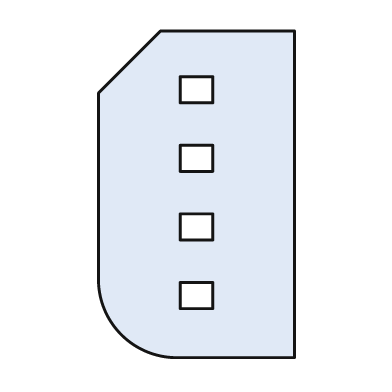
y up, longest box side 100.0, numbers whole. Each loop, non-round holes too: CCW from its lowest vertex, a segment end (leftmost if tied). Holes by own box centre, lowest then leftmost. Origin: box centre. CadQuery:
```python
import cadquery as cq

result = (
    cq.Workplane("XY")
    .moveTo(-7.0, -50.0)
    .lineTo(30.0, -50.0)
    .lineTo(30.0, 50.0)
    .lineTo(-11.0, 50.0)
    .lineTo(-30.0, 31.0)
    .lineTo(-30.0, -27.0)
    .threePointArc((-23.0, -43.0), (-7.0, -50.0))
    .close()
    .moveTo(-5.0, -35.0)
    .lineTo(5.0, -35.0)
    .lineTo(5.0, -27.0)
    .lineTo(-5.0, -27.0)
    .close()
    .moveTo(-5.0, -14.0)
    .lineTo(5.0, -14.0)
    .lineTo(5.0, -6.0)
    .lineTo(-5.0, -6.0)
    .close()
    .moveTo(-5.0, 7.0)
    .lineTo(5.0, 7.0)
    .lineTo(5.0, 15.0)
    .lineTo(-5.0, 15.0)
    .close()
    .moveTo(-5.0, 28.0)
    .lineTo(5.0, 28.0)
    .lineTo(5.0, 36.0)
    .lineTo(-5.0, 36.0)
    .close()
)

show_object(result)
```